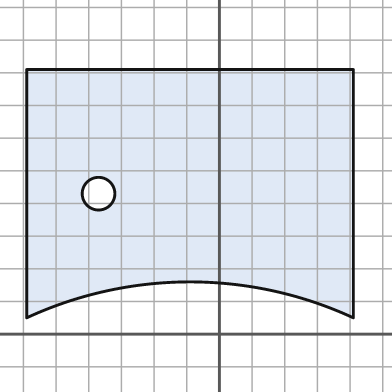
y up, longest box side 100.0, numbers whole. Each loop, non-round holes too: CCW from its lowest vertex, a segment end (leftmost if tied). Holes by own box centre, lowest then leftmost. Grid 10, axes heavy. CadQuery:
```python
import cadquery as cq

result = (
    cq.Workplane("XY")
    .moveTo(-59.0, 5.0)
    .threePointArc((-9.0, 16.0), (41.0, 5.0))
    .lineTo(41.0, 81.0)
    .lineTo(-59.0, 81.0)
    .close()
    .moveTo(-37.0, 43.0)
    .circle(5.0)
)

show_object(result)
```